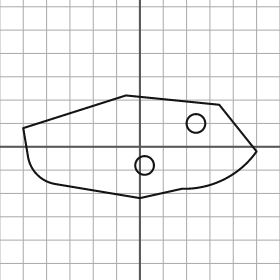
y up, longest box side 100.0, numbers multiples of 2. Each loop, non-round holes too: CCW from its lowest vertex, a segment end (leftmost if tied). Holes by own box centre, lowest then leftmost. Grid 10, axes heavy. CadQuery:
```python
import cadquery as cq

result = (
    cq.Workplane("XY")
    .moveTo(0.0, -22.0)
    .lineTo(18.0, -18.0)
    .threePointArc((36.0, -14.0), (50.0, -2.0))
    .lineTo(34.0, 18.0)
    .lineTo(-6.0, 22.0)
    .lineTo(-50.0, 8.0)
    .lineTo(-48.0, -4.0)
    .threePointArc((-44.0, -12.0), (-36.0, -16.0))
    .close()
    .moveTo(2.0, -8.0)
    .circle(4.0)
    .moveTo(24.0, 10.0)
    .circle(4.0)
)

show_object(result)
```